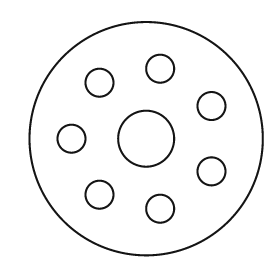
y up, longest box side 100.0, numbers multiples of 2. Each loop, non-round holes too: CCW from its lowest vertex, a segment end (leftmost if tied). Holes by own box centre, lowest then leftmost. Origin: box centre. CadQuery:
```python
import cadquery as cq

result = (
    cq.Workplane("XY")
    .moveTo(0.0, 0.0)
    .circle(50.0)
    .moveTo(6.0, -30.0)
    .circle(6.0)
    .moveTo(-20.0, -24.0)
    .circle(6.0)
    .moveTo(28.0, -14.0)
    .circle(6.0)
    .moveTo(-32.0, 0.0)
    .circle(6.0)
    .moveTo(0.0, 0.0)
    .circle(12.0)
    .moveTo(28.0, 14.0)
    .circle(6.0)
    .moveTo(-20.0, 24.0)
    .circle(6.0)
    .moveTo(6.0, 30.0)
    .circle(6.0)
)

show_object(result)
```